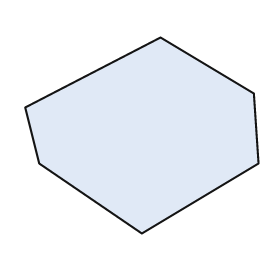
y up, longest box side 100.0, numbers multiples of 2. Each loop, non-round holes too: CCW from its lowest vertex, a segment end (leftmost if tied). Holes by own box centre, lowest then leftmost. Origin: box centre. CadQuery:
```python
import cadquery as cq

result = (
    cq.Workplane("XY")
    .moveTo(0.0, -42.0)
    .lineTo(50.0, -12.0)
    .lineTo(48.0, 18.0)
    .lineTo(8.0, 42.0)
    .lineTo(-50.0, 12.0)
    .lineTo(-44.0, -12.0)
    .close()
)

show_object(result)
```